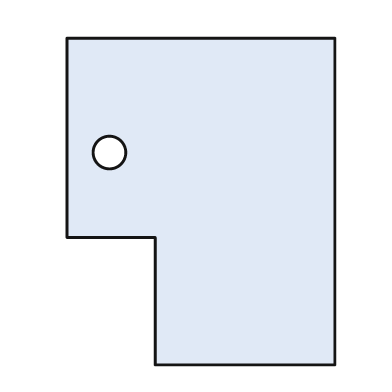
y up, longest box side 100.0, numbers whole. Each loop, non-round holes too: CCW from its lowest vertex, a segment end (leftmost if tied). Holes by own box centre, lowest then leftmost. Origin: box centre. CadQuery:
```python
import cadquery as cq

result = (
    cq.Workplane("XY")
    .moveTo(-14.0, -50.0)
    .lineTo(41.0, -50.0)
    .lineTo(41.0, 50.0)
    .lineTo(-41.0, 50.0)
    .lineTo(-41.0, -11.0)
    .lineTo(-14.0, -11.0)
    .close()
    .moveTo(-28.0, 15.0)
    .circle(5.0)
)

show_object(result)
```